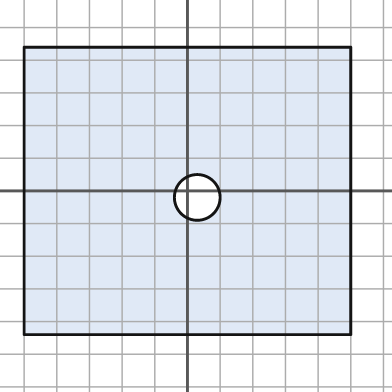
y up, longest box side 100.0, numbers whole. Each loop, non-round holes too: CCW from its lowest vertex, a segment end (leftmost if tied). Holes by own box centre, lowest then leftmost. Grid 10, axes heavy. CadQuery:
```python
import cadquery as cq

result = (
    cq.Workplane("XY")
    .moveTo(-50.0, -44.0)
    .lineTo(50.0, -44.0)
    .lineTo(50.0, 44.0)
    .lineTo(-50.0, 44.0)
    .close()
    .moveTo(3.0, -2.0)
    .circle(7.0)
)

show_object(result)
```